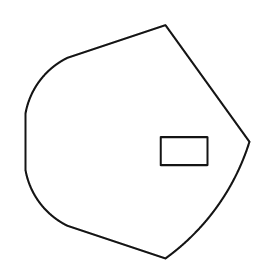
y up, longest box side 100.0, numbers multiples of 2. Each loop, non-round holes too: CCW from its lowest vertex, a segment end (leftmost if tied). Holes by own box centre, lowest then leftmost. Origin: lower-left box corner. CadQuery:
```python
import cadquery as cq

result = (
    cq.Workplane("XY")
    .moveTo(60.0, 0.0)
    .threePointArc((82.0, 22.0), (96.0, 50.0))
    .lineTo(60.0, 100.0)
    .lineTo(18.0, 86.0)
    .threePointArc((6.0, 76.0), (0.0, 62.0))
    .lineTo(0.0, 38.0)
    .threePointArc((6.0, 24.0), (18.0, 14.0))
    .close()
    .moveTo(58.0, 40.0)
    .lineTo(78.0, 40.0)
    .lineTo(78.0, 52.0)
    .lineTo(58.0, 52.0)
    .close()
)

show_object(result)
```